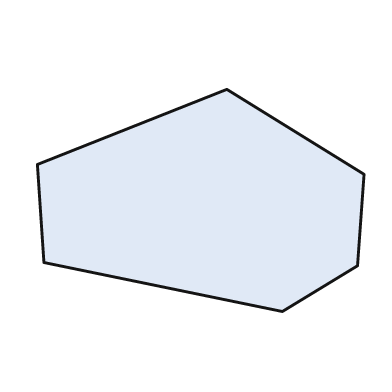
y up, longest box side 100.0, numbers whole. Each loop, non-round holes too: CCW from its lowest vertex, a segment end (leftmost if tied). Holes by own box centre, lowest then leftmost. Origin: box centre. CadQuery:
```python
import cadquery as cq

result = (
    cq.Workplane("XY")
    .moveTo(25.0, -34.0)
    .lineTo(48.0, -20.0)
    .lineTo(50.0, 8.0)
    .lineTo(8.0, 34.0)
    .lineTo(-50.0, 11.0)
    .lineTo(-48.0, -19.0)
    .close()
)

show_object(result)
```